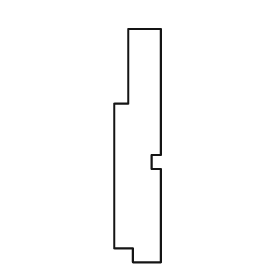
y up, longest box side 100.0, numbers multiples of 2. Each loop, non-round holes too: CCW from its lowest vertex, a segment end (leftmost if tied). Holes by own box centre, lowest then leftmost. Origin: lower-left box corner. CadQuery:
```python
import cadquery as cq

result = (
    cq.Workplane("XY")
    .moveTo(8.0, 0.0)
    .lineTo(20.0, 0.0)
    .lineTo(20.0, 40.0)
    .lineTo(16.0, 40.0)
    .lineTo(16.0, 46.0)
    .lineTo(20.0, 46.0)
    .lineTo(20.0, 100.0)
    .lineTo(6.0, 100.0)
    .lineTo(6.0, 68.0)
    .lineTo(0.0, 68.0)
    .lineTo(0.0, 6.0)
    .lineTo(8.0, 6.0)
    .close()
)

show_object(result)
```